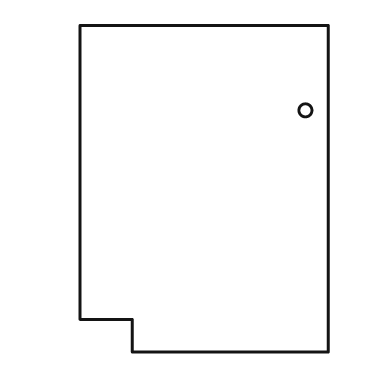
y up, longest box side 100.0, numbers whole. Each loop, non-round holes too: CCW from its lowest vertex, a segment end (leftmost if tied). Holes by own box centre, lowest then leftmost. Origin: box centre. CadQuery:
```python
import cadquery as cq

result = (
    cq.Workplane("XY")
    .moveTo(-22.0, -50.0)
    .lineTo(38.0, -50.0)
    .lineTo(38.0, 50.0)
    .lineTo(-38.0, 50.0)
    .lineTo(-38.0, -40.0)
    .lineTo(-22.0, -40.0)
    .close()
    .moveTo(31.0, 24.0)
    .circle(2.0)
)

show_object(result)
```